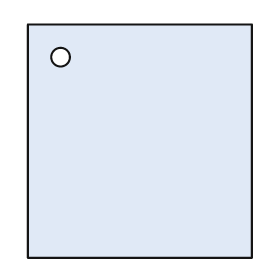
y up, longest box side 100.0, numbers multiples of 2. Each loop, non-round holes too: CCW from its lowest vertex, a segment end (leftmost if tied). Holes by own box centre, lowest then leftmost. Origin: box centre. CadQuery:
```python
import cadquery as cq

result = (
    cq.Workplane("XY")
    .moveTo(-48.0, -50.0)
    .lineTo(48.0, -50.0)
    .lineTo(48.0, 50.0)
    .lineTo(-48.0, 50.0)
    .close()
    .moveTo(-34.0, 36.0)
    .circle(4.0)
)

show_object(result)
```